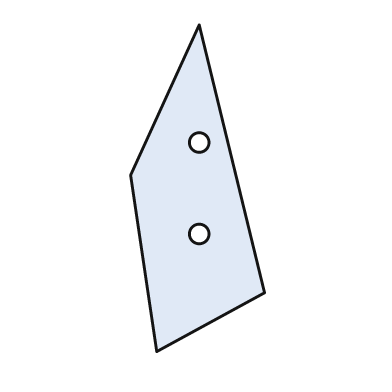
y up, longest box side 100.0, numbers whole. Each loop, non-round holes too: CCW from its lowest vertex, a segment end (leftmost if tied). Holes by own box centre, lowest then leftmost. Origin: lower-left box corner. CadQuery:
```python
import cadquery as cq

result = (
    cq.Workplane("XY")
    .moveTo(8.0, 0.0)
    .lineTo(41.0, 18.0)
    .lineTo(21.0, 100.0)
    .lineTo(0.0, 54.0)
    .close()
    .moveTo(21.0, 36.0)
    .circle(3.0)
    .moveTo(21.0, 64.0)
    .circle(3.0)
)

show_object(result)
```